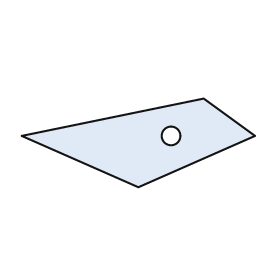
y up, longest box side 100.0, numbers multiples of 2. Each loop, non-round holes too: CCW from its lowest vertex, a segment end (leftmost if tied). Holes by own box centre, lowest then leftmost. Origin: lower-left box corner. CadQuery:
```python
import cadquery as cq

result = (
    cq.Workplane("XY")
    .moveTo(50.0, 0.0)
    .lineTo(100.0, 22.0)
    .lineTo(78.0, 38.0)
    .lineTo(0.0, 22.0)
    .close()
    .moveTo(64.0, 22.0)
    .circle(4.0)
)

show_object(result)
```